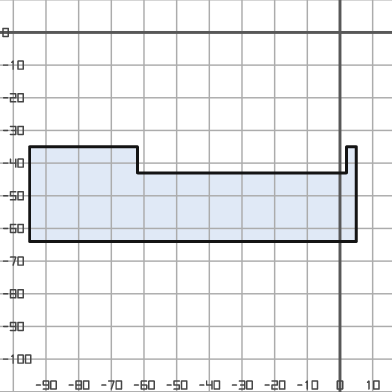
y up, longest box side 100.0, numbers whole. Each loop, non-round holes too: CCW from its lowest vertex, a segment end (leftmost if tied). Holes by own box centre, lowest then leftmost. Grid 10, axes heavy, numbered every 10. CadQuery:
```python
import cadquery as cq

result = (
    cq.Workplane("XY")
    .moveTo(-95.0, -64.0)
    .lineTo(5.0, -64.0)
    .lineTo(5.0, -35.0)
    .lineTo(2.0, -35.0)
    .lineTo(2.0, -43.0)
    .lineTo(-62.0, -43.0)
    .lineTo(-62.0, -35.0)
    .lineTo(-95.0, -35.0)
    .close()
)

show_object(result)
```